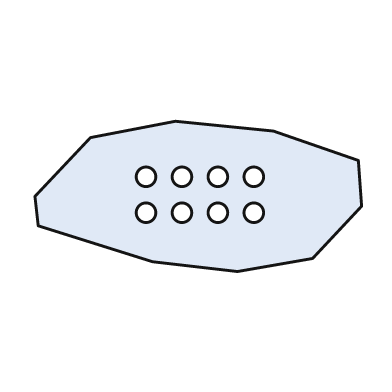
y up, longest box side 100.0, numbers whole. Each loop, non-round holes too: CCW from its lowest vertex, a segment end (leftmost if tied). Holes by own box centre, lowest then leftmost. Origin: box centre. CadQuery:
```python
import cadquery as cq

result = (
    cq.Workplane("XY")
    .moveTo(12.0, -23.0)
    .lineTo(35.0, -19.0)
    .lineTo(50.0, -3.0)
    .lineTo(49.0, 11.0)
    .lineTo(23.0, 20.0)
    .lineTo(-7.0, 23.0)
    .lineTo(-33.0, 18.0)
    .lineTo(-50.0, 0.0)
    .lineTo(-49.0, -9.0)
    .lineTo(-14.0, -20.0)
    .close()
    .moveTo(-16.0, -5.0)
    .circle(3.0)
    .moveTo(-5.0, -5.0)
    .circle(3.0)
    .moveTo(6.0, -5.0)
    .circle(3.0)
    .moveTo(17.0, -5.0)
    .circle(3.0)
    .moveTo(-16.0, 6.0)
    .circle(3.0)
    .moveTo(-5.0, 6.0)
    .circle(3.0)
    .moveTo(6.0, 6.0)
    .circle(3.0)
    .moveTo(17.0, 6.0)
    .circle(3.0)
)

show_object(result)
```